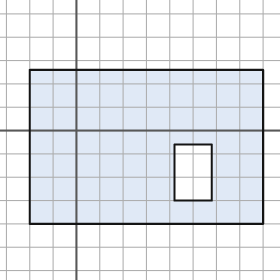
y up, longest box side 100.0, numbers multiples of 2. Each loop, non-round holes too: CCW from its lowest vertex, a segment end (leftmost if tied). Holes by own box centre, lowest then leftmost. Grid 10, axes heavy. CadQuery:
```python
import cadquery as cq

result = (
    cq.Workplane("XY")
    .moveTo(-20.0, -40.0)
    .lineTo(80.0, -40.0)
    .lineTo(80.0, 26.0)
    .lineTo(-20.0, 26.0)
    .close()
    .moveTo(42.0, -30.0)
    .lineTo(58.0, -30.0)
    .lineTo(58.0, -6.0)
    .lineTo(42.0, -6.0)
    .close()
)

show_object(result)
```